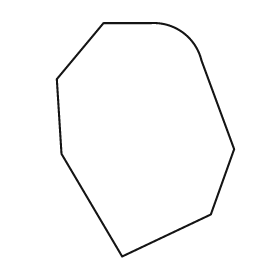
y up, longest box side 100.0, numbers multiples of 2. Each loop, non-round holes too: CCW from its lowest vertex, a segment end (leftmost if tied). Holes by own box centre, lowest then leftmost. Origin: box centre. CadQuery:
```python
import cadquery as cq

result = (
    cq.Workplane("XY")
    .moveTo(-10.0, -50.0)
    .lineTo(28.0, -32.0)
    .lineTo(38.0, -4.0)
    .lineTo(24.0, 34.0)
    .threePointArc((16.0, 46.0), (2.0, 50.0))
    .lineTo(-18.0, 50.0)
    .lineTo(-38.0, 26.0)
    .lineTo(-36.0, -6.0)
    .close()
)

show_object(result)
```